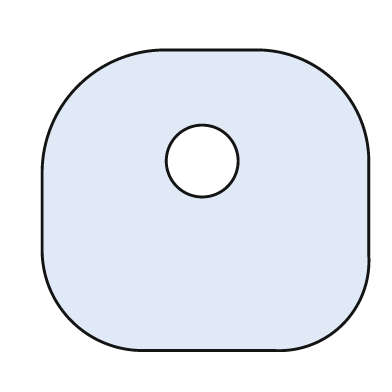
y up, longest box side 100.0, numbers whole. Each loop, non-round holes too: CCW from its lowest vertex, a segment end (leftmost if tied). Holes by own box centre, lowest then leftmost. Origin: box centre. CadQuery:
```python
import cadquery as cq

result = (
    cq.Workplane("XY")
    .moveTo(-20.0, -46.0)
    .lineTo(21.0, -46.0)
    .threePointArc((42.0, -38.0), (50.0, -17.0))
    .lineTo(50.0, 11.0)
    .threePointArc((40.0, 36.0), (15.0, 46.0))
    .lineTo(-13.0, 46.0)
    .threePointArc((-39.0, 35.0), (-50.0, 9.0))
    .lineTo(-50.0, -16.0)
    .threePointArc((-41.0, -37.0), (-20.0, -46.0))
    .close()
    .moveTo(-1.0, 12.0)
    .circle(11.0)
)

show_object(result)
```